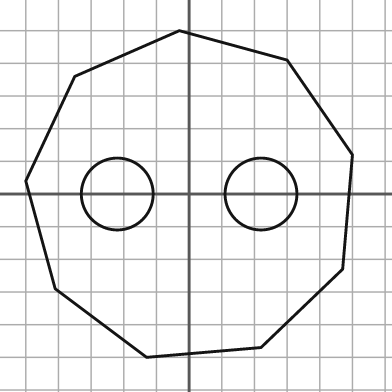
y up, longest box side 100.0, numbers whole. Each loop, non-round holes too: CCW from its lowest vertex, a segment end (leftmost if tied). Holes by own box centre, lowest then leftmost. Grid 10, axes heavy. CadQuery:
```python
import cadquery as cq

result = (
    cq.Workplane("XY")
    .moveTo(-13.0, -50.0)
    .lineTo(22.0, -47.0)
    .lineTo(47.0, -23.0)
    .lineTo(50.0, 12.0)
    .lineTo(30.0, 41.0)
    .lineTo(-3.0, 50.0)
    .lineTo(-35.0, 36.0)
    .lineTo(-50.0, 4.0)
    .lineTo(-41.0, -29.0)
    .close()
    .moveTo(-22.0, 0.0)
    .circle(11.0)
    .moveTo(22.0, 0.0)
    .circle(11.0)
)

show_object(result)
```